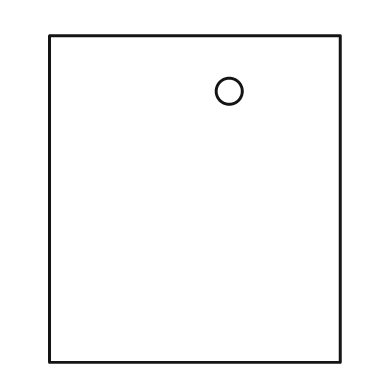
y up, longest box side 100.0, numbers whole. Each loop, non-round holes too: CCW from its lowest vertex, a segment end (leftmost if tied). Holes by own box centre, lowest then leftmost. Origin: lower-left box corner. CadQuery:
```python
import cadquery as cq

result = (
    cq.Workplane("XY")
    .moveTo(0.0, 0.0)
    .lineTo(89.0, 0.0)
    .lineTo(89.0, 100.0)
    .lineTo(0.0, 100.0)
    .close()
    .moveTo(55.0, 83.0)
    .circle(4.0)
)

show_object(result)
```